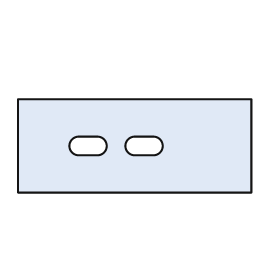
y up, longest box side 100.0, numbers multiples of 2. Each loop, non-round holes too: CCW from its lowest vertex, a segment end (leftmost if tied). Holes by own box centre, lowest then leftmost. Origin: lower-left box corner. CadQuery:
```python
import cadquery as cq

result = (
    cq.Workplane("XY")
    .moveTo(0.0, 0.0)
    .lineTo(100.0, 0.0)
    .lineTo(100.0, 40.0)
    .lineTo(0.0, 40.0)
    .close()
    .moveTo(26.0, 16.0)
    .lineTo(34.0, 16.0)
    .threePointArc((38.0, 20.0), (34.0, 24.0))
    .lineTo(26.0, 24.0)
    .threePointArc((22.0, 20.0), (26.0, 16.0))
    .close()
    .moveTo(50.0, 16.0)
    .lineTo(58.0, 16.0)
    .threePointArc((62.0, 20.0), (58.0, 24.0))
    .lineTo(50.0, 24.0)
    .threePointArc((46.0, 20.0), (50.0, 16.0))
    .close()
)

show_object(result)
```